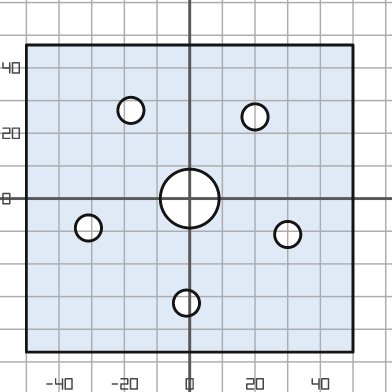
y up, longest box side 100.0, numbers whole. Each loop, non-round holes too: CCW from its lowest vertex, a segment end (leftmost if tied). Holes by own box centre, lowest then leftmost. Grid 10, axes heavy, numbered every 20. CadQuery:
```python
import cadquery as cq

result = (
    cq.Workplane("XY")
    .moveTo(-50.0, -47.0)
    .lineTo(50.0, -47.0)
    .lineTo(50.0, 47.0)
    .lineTo(-50.0, 47.0)
    .close()
    .moveTo(-1.0, -32.0)
    .circle(4.0)
    .moveTo(30.0, -11.0)
    .circle(4.0)
    .moveTo(-31.0, -9.0)
    .circle(4.0)
    .moveTo(0.0, 0.0)
    .circle(9.0)
    .moveTo(20.0, 25.0)
    .circle(4.0)
    .moveTo(-18.0, 27.0)
    .circle(4.0)
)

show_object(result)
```